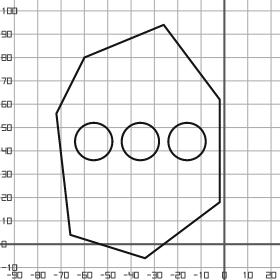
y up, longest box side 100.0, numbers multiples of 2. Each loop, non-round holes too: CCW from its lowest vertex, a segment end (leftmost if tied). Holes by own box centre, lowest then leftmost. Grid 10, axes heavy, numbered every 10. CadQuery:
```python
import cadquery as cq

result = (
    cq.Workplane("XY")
    .moveTo(-34.0, -6.0)
    .lineTo(-2.0, 18.0)
    .lineTo(-2.0, 62.0)
    .lineTo(-26.0, 94.0)
    .lineTo(-60.0, 80.0)
    .lineTo(-72.0, 56.0)
    .lineTo(-66.0, 4.0)
    .close()
    .moveTo(-56.0, 44.0)
    .circle(8.0)
    .moveTo(-36.0, 44.0)
    .circle(8.0)
    .moveTo(-16.0, 44.0)
    .circle(8.0)
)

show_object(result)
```